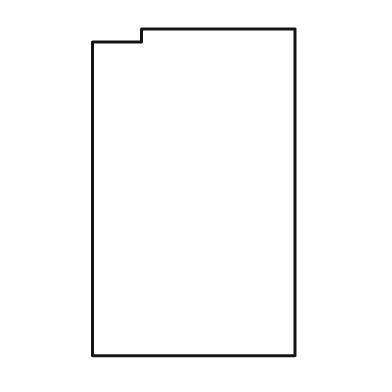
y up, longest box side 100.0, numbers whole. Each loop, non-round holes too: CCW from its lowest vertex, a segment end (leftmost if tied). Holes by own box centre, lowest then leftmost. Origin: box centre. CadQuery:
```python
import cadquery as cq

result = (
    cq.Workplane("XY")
    .moveTo(-31.0, -50.0)
    .lineTo(31.0, -50.0)
    .lineTo(31.0, 50.0)
    .lineTo(-16.0, 50.0)
    .lineTo(-16.0, 46.0)
    .lineTo(-31.0, 46.0)
    .close()
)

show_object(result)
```